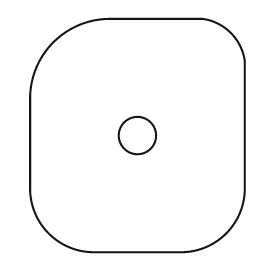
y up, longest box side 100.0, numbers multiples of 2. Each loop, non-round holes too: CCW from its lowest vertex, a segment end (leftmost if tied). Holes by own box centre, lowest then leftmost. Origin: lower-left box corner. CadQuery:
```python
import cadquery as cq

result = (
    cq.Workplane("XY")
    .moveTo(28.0, 0.0)
    .lineTo(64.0, 0.0)
    .threePointArc((84.0, 8.0), (92.0, 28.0))
    .lineTo(92.0, 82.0)
    .threePointArc((86.0, 94.0), (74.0, 100.0))
    .lineTo(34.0, 100.0)
    .threePointArc((10.0, 90.0), (0.0, 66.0))
    .lineTo(0.0, 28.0)
    .threePointArc((8.0, 8.0), (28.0, 0.0))
    .close()
    .moveTo(46.0, 50.0)
    .circle(8.0)
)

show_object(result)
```